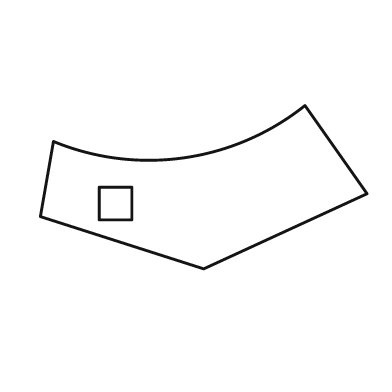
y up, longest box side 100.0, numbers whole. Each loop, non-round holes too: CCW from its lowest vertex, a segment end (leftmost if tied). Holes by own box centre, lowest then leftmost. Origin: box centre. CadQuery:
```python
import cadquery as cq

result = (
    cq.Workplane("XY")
    .moveTo(0.0, -25.0)
    .lineTo(50.0, -2.0)
    .lineTo(31.0, 25.0)
    .threePointArc((-6.0, 9.0), (-46.0, 14.0))
    .lineTo(-50.0, -9.0)
    .close()
    .moveTo(-32.0, -10.0)
    .lineTo(-22.0, -10.0)
    .lineTo(-22.0, 0.0)
    .lineTo(-32.0, 0.0)
    .close()
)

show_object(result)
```